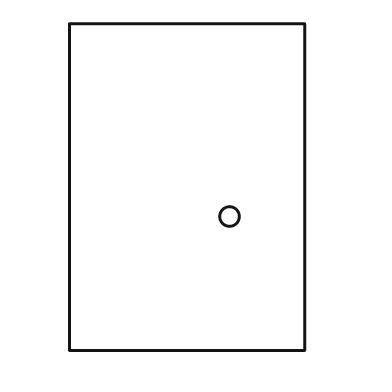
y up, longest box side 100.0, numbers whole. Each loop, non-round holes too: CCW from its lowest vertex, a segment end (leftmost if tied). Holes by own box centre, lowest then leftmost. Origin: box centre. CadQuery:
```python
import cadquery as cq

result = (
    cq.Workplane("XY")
    .moveTo(-36.0, -50.0)
    .lineTo(36.0, -50.0)
    .lineTo(36.0, 50.0)
    .lineTo(-36.0, 50.0)
    .close()
    .moveTo(13.0, -9.0)
    .circle(3.0)
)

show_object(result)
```